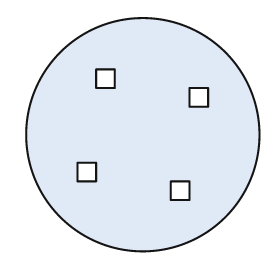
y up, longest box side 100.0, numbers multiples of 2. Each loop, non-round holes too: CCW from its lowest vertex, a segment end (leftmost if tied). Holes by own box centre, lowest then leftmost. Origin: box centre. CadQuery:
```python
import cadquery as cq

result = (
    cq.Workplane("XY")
    .moveTo(0.0, 0.0)
    .circle(50.0)
    .moveTo(12.0, -28.0)
    .lineTo(20.0, -28.0)
    .lineTo(20.0, -20.0)
    .lineTo(12.0, -20.0)
    .close()
    .moveTo(-28.0, -20.0)
    .lineTo(-20.0, -20.0)
    .lineTo(-20.0, -12.0)
    .lineTo(-28.0, -12.0)
    .close()
    .moveTo(20.0, 12.0)
    .lineTo(28.0, 12.0)
    .lineTo(28.0, 20.0)
    .lineTo(20.0, 20.0)
    .close()
    .moveTo(-20.0, 20.0)
    .lineTo(-12.0, 20.0)
    .lineTo(-12.0, 28.0)
    .lineTo(-20.0, 28.0)
    .close()
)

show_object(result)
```